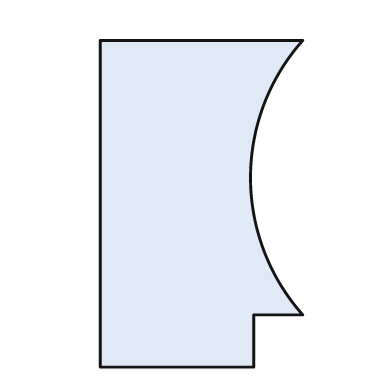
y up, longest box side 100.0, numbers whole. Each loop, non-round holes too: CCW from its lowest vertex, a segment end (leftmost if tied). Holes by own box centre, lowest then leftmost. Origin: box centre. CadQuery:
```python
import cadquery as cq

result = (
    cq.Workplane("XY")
    .moveTo(-31.0, -50.0)
    .lineTo(16.0, -50.0)
    .lineTo(16.0, -34.0)
    .lineTo(31.0, -34.0)
    .threePointArc((15.0, 8.0), (31.0, 50.0))
    .lineTo(-31.0, 50.0)
    .close()
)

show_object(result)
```